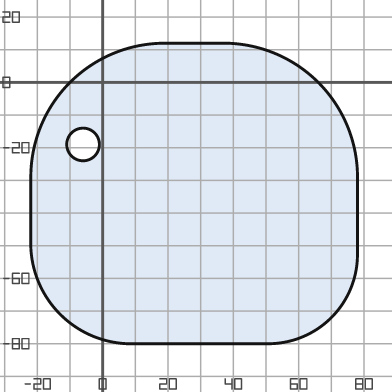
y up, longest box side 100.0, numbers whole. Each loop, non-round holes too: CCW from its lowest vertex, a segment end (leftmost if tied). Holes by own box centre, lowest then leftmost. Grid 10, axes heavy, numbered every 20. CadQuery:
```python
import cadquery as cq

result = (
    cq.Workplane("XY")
    .moveTo(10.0, -80.0)
    .lineTo(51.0, -80.0)
    .threePointArc((70.0, -72.0), (78.0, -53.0))
    .lineTo(78.0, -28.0)
    .threePointArc((66.0, 0.0), (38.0, 12.0))
    .lineTo(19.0, 12.0)
    .threePointArc((-10.0, 0.0), (-22.0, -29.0))
    .lineTo(-22.0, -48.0)
    .threePointArc((-13.0, -71.0), (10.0, -80.0))
    .close()
    .moveTo(-6.0, -19.0)
    .circle(5.0)
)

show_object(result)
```